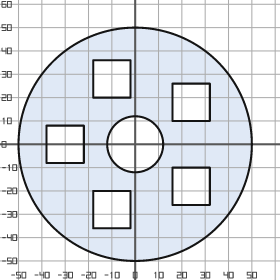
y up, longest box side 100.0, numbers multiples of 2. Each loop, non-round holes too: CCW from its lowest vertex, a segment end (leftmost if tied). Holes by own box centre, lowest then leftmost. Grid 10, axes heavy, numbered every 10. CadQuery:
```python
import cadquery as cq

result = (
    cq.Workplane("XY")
    .moveTo(0.0, 0.0)
    .circle(50.0)
    .moveTo(-18.0, -36.0)
    .lineTo(-2.0, -36.0)
    .lineTo(-2.0, -20.0)
    .lineTo(-18.0, -20.0)
    .close()
    .moveTo(16.0, -26.0)
    .lineTo(32.0, -26.0)
    .lineTo(32.0, -10.0)
    .lineTo(16.0, -10.0)
    .close()
    .moveTo(-38.0, -8.0)
    .lineTo(-22.0, -8.0)
    .lineTo(-22.0, 8.0)
    .lineTo(-38.0, 8.0)
    .close()
    .moveTo(0.0, 0.0)
    .circle(12.0)
    .moveTo(16.0, 10.0)
    .lineTo(32.0, 10.0)
    .lineTo(32.0, 26.0)
    .lineTo(16.0, 26.0)
    .close()
    .moveTo(-18.0, 20.0)
    .lineTo(-2.0, 20.0)
    .lineTo(-2.0, 36.0)
    .lineTo(-18.0, 36.0)
    .close()
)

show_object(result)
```